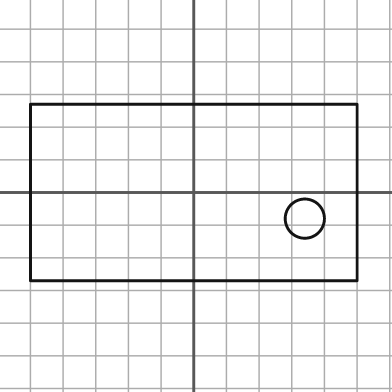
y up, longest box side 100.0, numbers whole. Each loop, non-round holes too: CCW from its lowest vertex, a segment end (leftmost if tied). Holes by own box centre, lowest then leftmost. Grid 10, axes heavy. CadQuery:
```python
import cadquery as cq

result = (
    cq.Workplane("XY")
    .moveTo(-50.0, -27.0)
    .lineTo(50.0, -27.0)
    .lineTo(50.0, 27.0)
    .lineTo(-50.0, 27.0)
    .close()
    .moveTo(34.0, -8.0)
    .circle(6.0)
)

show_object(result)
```